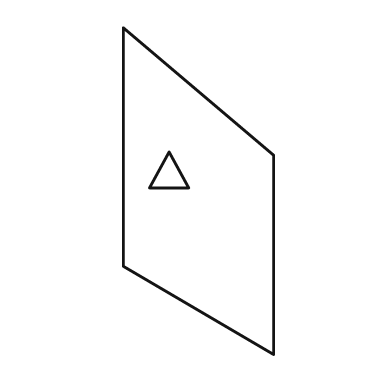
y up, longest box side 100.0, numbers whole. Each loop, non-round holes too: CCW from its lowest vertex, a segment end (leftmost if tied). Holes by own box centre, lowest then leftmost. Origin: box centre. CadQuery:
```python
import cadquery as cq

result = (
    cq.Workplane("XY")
    .moveTo(23.0, -50.0)
    .lineTo(23.0, 11.0)
    .lineTo(-23.0, 50.0)
    .lineTo(-23.0, -23.0)
    .close()
    .moveTo(-15.0, 1.0)
    .lineTo(-3.0, 1.0)
    .lineTo(-9.0, 12.0)
    .close()
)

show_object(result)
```